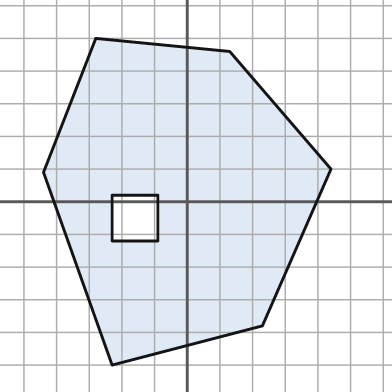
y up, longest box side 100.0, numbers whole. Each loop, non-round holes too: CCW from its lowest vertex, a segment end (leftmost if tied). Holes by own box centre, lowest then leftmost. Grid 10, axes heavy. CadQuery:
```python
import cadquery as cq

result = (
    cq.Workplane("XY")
    .moveTo(-23.0, -50.0)
    .lineTo(23.0, -38.0)
    .lineTo(44.0, 10.0)
    .lineTo(13.0, 46.0)
    .lineTo(-28.0, 50.0)
    .lineTo(-44.0, 9.0)
    .close()
    .moveTo(-23.0, -12.0)
    .lineTo(-9.0, -12.0)
    .lineTo(-9.0, 2.0)
    .lineTo(-23.0, 2.0)
    .close()
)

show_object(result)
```